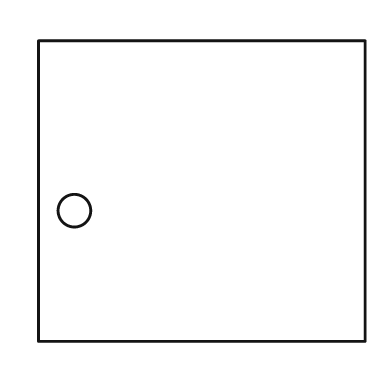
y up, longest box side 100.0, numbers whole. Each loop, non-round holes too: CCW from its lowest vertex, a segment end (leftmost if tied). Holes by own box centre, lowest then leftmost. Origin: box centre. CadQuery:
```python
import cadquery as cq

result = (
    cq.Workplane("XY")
    .moveTo(-50.0, -46.0)
    .lineTo(50.0, -46.0)
    .lineTo(50.0, 46.0)
    .lineTo(-50.0, 46.0)
    .close()
    .moveTo(-39.0, -6.0)
    .circle(5.0)
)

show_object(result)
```